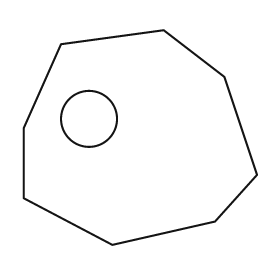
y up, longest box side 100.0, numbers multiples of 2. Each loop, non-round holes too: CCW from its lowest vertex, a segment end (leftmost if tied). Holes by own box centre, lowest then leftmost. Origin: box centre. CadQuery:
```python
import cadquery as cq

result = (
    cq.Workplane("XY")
    .moveTo(-12.0, -46.0)
    .lineTo(32.0, -36.0)
    .lineTo(50.0, -16.0)
    .lineTo(36.0, 26.0)
    .lineTo(10.0, 46.0)
    .lineTo(-34.0, 40.0)
    .lineTo(-50.0, 4.0)
    .lineTo(-50.0, -26.0)
    .close()
    .moveTo(-22.0, 8.0)
    .circle(12.0)
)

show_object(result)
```